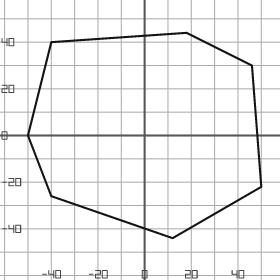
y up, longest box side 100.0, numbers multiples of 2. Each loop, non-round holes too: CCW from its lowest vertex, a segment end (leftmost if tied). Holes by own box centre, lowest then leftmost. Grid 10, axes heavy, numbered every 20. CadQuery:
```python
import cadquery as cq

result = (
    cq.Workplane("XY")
    .moveTo(12.0, -44.0)
    .lineTo(50.0, -22.0)
    .lineTo(46.0, 30.0)
    .lineTo(18.0, 44.0)
    .lineTo(-40.0, 40.0)
    .lineTo(-50.0, 0.0)
    .lineTo(-40.0, -26.0)
    .close()
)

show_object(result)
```